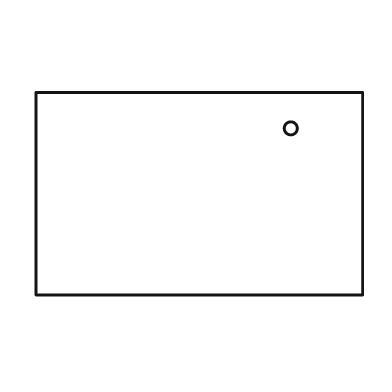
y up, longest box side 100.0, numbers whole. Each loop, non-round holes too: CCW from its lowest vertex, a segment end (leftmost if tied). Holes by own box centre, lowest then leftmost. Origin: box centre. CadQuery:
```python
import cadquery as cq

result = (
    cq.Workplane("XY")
    .moveTo(-50.0, -31.0)
    .lineTo(50.0, -31.0)
    .lineTo(50.0, 31.0)
    .lineTo(-50.0, 31.0)
    .close()
    .moveTo(28.0, 20.0)
    .circle(2.0)
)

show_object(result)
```